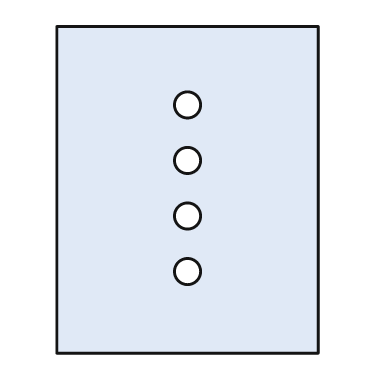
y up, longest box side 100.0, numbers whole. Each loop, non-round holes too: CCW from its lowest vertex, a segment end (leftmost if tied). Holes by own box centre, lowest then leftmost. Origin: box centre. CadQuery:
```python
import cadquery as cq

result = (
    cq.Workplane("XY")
    .moveTo(-40.0, -50.0)
    .lineTo(40.0, -50.0)
    .lineTo(40.0, 50.0)
    .lineTo(-40.0, 50.0)
    .close()
    .moveTo(0.0, -25.0)
    .circle(4.0)
    .moveTo(0.0, -8.0)
    .circle(4.0)
    .moveTo(0.0, 9.0)
    .circle(4.0)
    .moveTo(0.0, 26.0)
    .circle(4.0)
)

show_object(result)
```